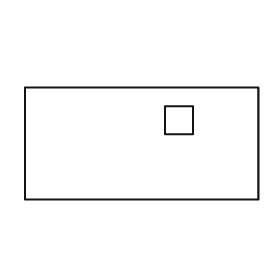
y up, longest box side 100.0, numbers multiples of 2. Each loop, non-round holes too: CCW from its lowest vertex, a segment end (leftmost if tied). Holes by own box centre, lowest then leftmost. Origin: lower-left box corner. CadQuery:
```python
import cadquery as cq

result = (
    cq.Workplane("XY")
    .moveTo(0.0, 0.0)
    .lineTo(100.0, 0.0)
    .lineTo(100.0, 48.0)
    .lineTo(0.0, 48.0)
    .close()
    .moveTo(60.0, 28.0)
    .lineTo(72.0, 28.0)
    .lineTo(72.0, 40.0)
    .lineTo(60.0, 40.0)
    .close()
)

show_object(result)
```